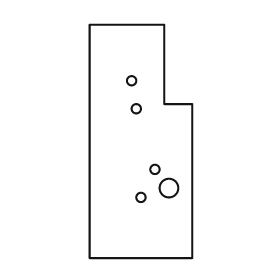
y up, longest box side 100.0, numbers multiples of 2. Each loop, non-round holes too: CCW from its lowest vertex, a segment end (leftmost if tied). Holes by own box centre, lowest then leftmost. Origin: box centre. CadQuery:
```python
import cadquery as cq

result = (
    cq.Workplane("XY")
    .moveTo(-22.0, -50.0)
    .lineTo(22.0, -50.0)
    .lineTo(22.0, 16.0)
    .lineTo(10.0, 16.0)
    .lineTo(10.0, 50.0)
    .lineTo(-22.0, 50.0)
    .close()
    .moveTo(0.0, -24.0)
    .circle(2.0)
    .moveTo(12.0, -20.0)
    .circle(4.0)
    .moveTo(6.0, -12.0)
    .circle(2.0)
    .moveTo(-2.0, 14.0)
    .circle(2.0)
    .moveTo(-4.0, 26.0)
    .circle(2.0)
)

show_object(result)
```